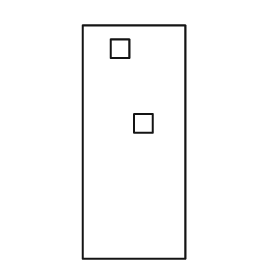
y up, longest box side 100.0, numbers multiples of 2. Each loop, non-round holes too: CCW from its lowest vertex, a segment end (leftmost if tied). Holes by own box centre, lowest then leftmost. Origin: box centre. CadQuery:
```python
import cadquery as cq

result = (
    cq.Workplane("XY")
    .moveTo(-22.0, -50.0)
    .lineTo(22.0, -50.0)
    .lineTo(22.0, 50.0)
    .lineTo(-22.0, 50.0)
    .close()
    .moveTo(0.0, 4.0)
    .lineTo(8.0, 4.0)
    .lineTo(8.0, 12.0)
    .lineTo(0.0, 12.0)
    .close()
    .moveTo(-10.0, 36.0)
    .lineTo(-2.0, 36.0)
    .lineTo(-2.0, 44.0)
    .lineTo(-10.0, 44.0)
    .close()
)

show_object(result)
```